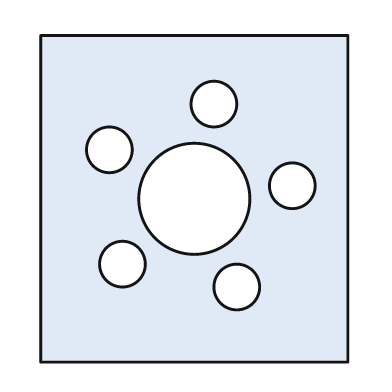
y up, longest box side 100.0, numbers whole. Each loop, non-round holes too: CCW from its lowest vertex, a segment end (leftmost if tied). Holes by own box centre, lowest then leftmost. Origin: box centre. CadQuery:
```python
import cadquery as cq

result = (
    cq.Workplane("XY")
    .moveTo(-47.0, -50.0)
    .lineTo(47.0, -50.0)
    .lineTo(47.0, 50.0)
    .lineTo(-47.0, 50.0)
    .close()
    .moveTo(13.0, -27.0)
    .circle(7.0)
    .moveTo(-22.0, -20.0)
    .circle(7.0)
    .moveTo(0.0, 0.0)
    .circle(17.0)
    .moveTo(30.0, 4.0)
    .circle(7.0)
    .moveTo(-26.0, 15.0)
    .circle(7.0)
    .moveTo(6.0, 29.0)
    .circle(7.0)
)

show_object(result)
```